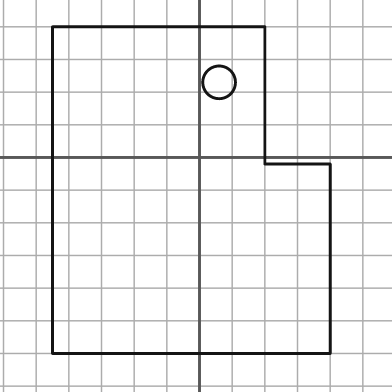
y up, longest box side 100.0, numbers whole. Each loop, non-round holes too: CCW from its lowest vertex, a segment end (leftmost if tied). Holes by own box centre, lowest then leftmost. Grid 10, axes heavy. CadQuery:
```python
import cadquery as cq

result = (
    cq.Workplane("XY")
    .moveTo(-45.0, -60.0)
    .lineTo(40.0, -60.0)
    .lineTo(40.0, -2.0)
    .lineTo(20.0, -2.0)
    .lineTo(20.0, 40.0)
    .lineTo(-45.0, 40.0)
    .close()
    .moveTo(6.0, 23.0)
    .circle(5.0)
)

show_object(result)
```